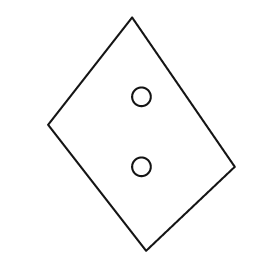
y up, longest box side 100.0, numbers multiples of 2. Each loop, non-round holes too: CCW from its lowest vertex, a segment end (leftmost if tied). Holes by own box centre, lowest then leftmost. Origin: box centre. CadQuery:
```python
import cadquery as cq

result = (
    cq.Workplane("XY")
    .moveTo(2.0, -50.0)
    .lineTo(40.0, -14.0)
    .lineTo(-4.0, 50.0)
    .lineTo(-40.0, 4.0)
    .close()
    .moveTo(0.0, -14.0)
    .circle(4.0)
    .moveTo(0.0, 16.0)
    .circle(4.0)
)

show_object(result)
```